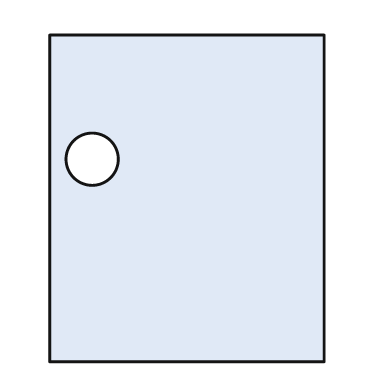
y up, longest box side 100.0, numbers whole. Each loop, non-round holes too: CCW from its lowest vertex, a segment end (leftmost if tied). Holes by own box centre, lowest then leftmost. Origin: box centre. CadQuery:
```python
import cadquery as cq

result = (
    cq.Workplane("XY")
    .moveTo(-42.0, -50.0)
    .lineTo(42.0, -50.0)
    .lineTo(42.0, 50.0)
    .lineTo(-42.0, 50.0)
    .close()
    .moveTo(-29.0, 12.0)
    .circle(8.0)
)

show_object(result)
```